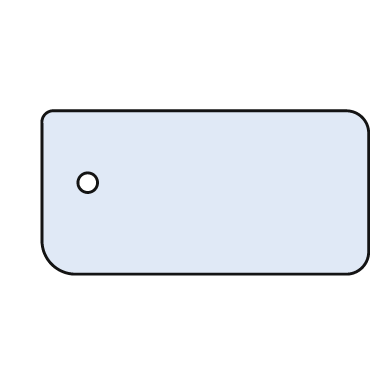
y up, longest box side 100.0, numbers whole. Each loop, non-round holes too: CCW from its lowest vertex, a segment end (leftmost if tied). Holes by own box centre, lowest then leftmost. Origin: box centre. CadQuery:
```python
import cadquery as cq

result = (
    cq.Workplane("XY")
    .moveTo(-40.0, -25.0)
    .lineTo(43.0, -25.0)
    .threePointArc((48.0, -23.0), (50.0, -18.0))
    .lineTo(50.0, 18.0)
    .threePointArc((48.0, 23.0), (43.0, 25.0))
    .lineTo(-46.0, 25.0)
    .threePointArc((-49.0, 24.0), (-50.0, 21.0))
    .lineTo(-50.0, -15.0)
    .threePointArc((-47.0, -22.0), (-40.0, -25.0))
    .close()
    .moveTo(-36.0, 3.0)
    .circle(3.0)
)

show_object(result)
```